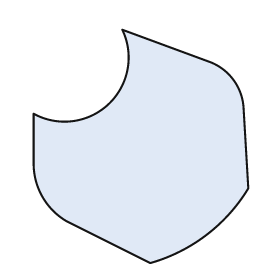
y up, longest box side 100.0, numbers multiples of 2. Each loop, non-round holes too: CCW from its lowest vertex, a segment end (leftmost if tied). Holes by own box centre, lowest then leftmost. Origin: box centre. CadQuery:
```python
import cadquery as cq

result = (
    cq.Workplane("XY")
    .moveTo(4.0, -50.0)
    .threePointArc((28.0, -38.0), (46.0, -18.0))
    .lineTo(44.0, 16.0)
    .threePointArc((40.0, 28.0), (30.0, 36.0))
    .lineTo(-8.0, 50.0)
    .threePointArc((-14.0, 18.0), (-46.0, 14.0))
    .lineTo(-46.0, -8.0)
    .threePointArc((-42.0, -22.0), (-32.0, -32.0))
    .close()
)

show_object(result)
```